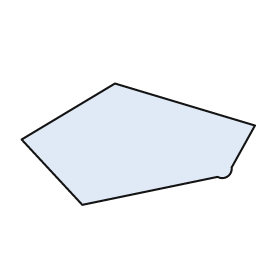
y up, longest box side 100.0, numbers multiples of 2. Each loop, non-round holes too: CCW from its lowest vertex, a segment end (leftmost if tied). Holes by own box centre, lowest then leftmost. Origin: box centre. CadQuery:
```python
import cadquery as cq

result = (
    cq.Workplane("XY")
    .moveTo(-24.0, -26.0)
    .lineTo(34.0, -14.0)
    .threePointArc((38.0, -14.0), (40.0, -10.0))
    .lineTo(50.0, 8.0)
    .lineTo(-10.0, 26.0)
    .lineTo(-50.0, 2.0)
    .close()
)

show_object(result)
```